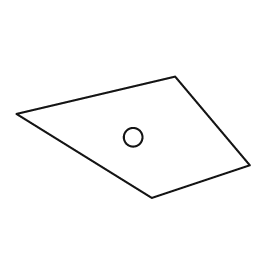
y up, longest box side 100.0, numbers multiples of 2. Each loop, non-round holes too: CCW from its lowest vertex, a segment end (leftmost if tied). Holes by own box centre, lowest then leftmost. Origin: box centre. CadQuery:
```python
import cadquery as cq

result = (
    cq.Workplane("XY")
    .moveTo(8.0, -26.0)
    .lineTo(50.0, -12.0)
    .lineTo(18.0, 26.0)
    .lineTo(-50.0, 10.0)
    .close()
    .moveTo(0.0, 0.0)
    .circle(4.0)
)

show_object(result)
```